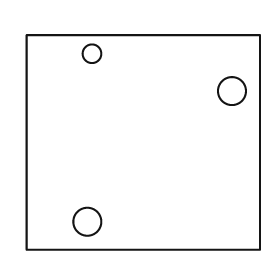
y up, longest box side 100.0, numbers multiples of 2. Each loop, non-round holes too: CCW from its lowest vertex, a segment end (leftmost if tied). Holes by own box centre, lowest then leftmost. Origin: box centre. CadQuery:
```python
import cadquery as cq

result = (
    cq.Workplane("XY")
    .moveTo(-50.0, -46.0)
    .lineTo(50.0, -46.0)
    .lineTo(50.0, 46.0)
    .lineTo(-50.0, 46.0)
    .close()
    .moveTo(-24.0, -34.0)
    .circle(6.0)
    .moveTo(38.0, 22.0)
    .circle(6.0)
    .moveTo(-22.0, 38.0)
    .circle(4.0)
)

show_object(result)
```